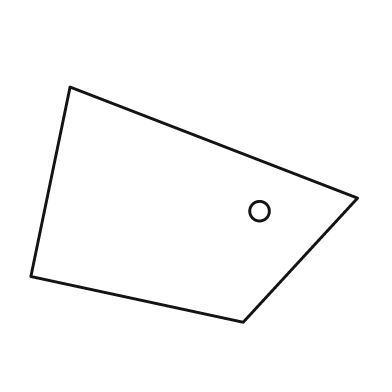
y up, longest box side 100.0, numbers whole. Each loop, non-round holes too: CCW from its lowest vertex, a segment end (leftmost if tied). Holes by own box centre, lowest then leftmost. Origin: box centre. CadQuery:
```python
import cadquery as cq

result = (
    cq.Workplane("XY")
    .moveTo(15.0, -36.0)
    .lineTo(50.0, 2.0)
    .lineTo(-38.0, 36.0)
    .lineTo(-50.0, -22.0)
    .close()
    .moveTo(20.0, -2.0)
    .circle(3.0)
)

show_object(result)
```